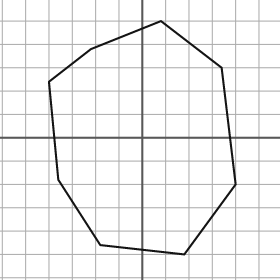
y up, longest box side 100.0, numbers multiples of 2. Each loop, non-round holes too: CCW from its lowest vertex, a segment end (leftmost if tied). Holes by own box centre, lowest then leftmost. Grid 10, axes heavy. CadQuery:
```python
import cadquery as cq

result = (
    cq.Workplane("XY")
    .moveTo(18.0, -50.0)
    .lineTo(40.0, -20.0)
    .lineTo(34.0, 30.0)
    .lineTo(8.0, 50.0)
    .lineTo(-22.0, 38.0)
    .lineTo(-40.0, 24.0)
    .lineTo(-36.0, -18.0)
    .lineTo(-18.0, -46.0)
    .close()
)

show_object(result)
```